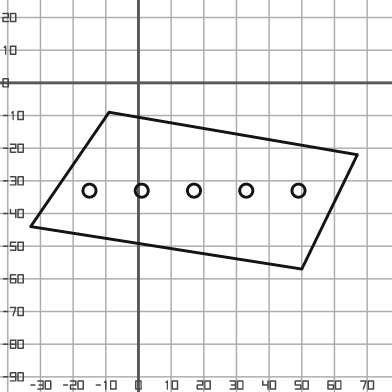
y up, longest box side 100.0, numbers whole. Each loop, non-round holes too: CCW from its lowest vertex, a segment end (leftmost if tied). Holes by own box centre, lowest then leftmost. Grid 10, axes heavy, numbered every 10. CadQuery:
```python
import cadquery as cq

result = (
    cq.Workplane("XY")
    .moveTo(50.0, -57.0)
    .lineTo(67.0, -22.0)
    .lineTo(-9.0, -9.0)
    .lineTo(-33.0, -44.0)
    .close()
    .moveTo(-15.0, -33.0)
    .circle(2.0)
    .moveTo(1.0, -33.0)
    .circle(2.0)
    .moveTo(17.0, -33.0)
    .circle(2.0)
    .moveTo(33.0, -33.0)
    .circle(2.0)
    .moveTo(49.0, -33.0)
    .circle(2.0)
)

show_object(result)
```